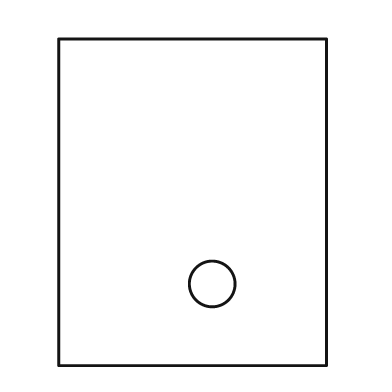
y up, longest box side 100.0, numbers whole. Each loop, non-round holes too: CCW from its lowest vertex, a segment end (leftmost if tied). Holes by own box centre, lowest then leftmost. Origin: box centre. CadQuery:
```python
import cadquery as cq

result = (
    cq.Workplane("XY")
    .moveTo(-41.0, -50.0)
    .lineTo(41.0, -50.0)
    .lineTo(41.0, 50.0)
    .lineTo(-41.0, 50.0)
    .close()
    .moveTo(6.0, -25.0)
    .circle(7.0)
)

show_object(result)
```